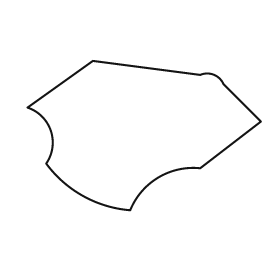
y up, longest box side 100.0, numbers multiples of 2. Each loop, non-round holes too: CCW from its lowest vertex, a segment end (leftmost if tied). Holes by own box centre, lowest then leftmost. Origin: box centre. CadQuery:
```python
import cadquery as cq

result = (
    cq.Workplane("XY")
    .moveTo(-6.0, -32.0)
    .threePointArc((6.0, -18.0), (24.0, -14.0))
    .lineTo(50.0, 6.0)
    .lineTo(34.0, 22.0)
    .threePointArc((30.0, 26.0), (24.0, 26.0))
    .lineTo(-22.0, 32.0)
    .lineTo(-50.0, 12.0)
    .threePointArc((-40.0, 2.0), (-42.0, -12.0))
    .threePointArc((-26.0, -26.0), (-6.0, -32.0))
    .close()
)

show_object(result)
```